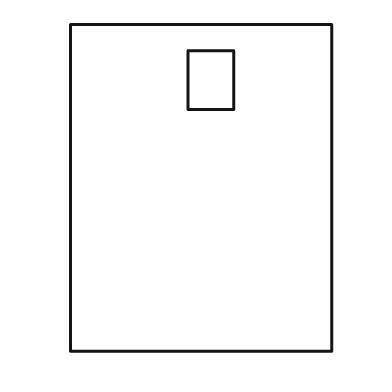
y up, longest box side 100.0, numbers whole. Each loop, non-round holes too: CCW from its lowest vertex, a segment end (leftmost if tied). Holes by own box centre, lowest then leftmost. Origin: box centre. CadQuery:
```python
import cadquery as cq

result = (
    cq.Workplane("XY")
    .moveTo(-40.0, -50.0)
    .lineTo(40.0, -50.0)
    .lineTo(40.0, 50.0)
    .lineTo(-40.0, 50.0)
    .close()
    .moveTo(-4.0, 24.0)
    .lineTo(10.0, 24.0)
    .lineTo(10.0, 42.0)
    .lineTo(-4.0, 42.0)
    .close()
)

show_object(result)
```